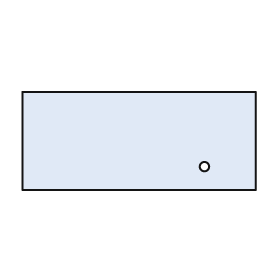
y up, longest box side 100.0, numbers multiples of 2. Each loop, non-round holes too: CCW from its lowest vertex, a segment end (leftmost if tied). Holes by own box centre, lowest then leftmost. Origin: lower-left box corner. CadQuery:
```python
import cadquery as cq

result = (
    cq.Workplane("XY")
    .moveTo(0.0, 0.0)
    .lineTo(100.0, 0.0)
    .lineTo(100.0, 42.0)
    .lineTo(0.0, 42.0)
    .close()
    .moveTo(78.0, 10.0)
    .circle(2.0)
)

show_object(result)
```